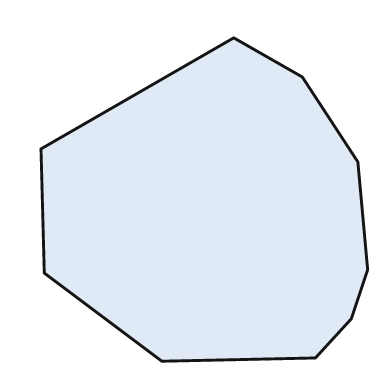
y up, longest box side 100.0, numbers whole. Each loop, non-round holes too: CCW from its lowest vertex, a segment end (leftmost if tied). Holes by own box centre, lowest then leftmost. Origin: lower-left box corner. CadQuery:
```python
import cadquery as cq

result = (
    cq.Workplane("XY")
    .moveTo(37.0, 0.0)
    .lineTo(84.0, 1.0)
    .lineTo(95.0, 13.0)
    .lineTo(100.0, 28.0)
    .lineTo(97.0, 61.0)
    .lineTo(80.0, 87.0)
    .lineTo(59.0, 99.0)
    .lineTo(0.0, 65.0)
    .lineTo(1.0, 27.0)
    .close()
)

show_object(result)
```